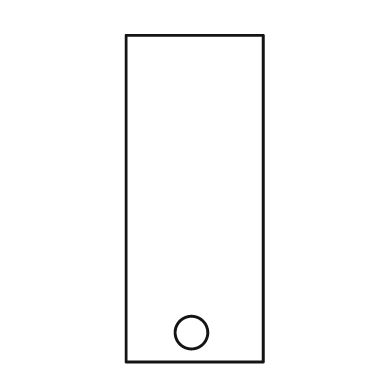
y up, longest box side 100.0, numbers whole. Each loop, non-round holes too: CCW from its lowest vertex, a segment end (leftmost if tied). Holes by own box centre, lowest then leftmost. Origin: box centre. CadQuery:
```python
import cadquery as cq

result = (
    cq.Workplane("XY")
    .moveTo(-21.0, -50.0)
    .lineTo(21.0, -50.0)
    .lineTo(21.0, 50.0)
    .lineTo(-21.0, 50.0)
    .close()
    .moveTo(-1.0, -41.0)
    .circle(5.0)
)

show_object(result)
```